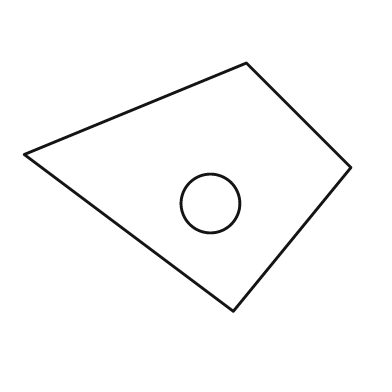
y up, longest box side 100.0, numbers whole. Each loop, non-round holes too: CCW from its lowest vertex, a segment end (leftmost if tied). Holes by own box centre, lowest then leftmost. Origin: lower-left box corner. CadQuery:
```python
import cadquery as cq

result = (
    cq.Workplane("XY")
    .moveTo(64.0, 0.0)
    .lineTo(100.0, 44.0)
    .lineTo(68.0, 76.0)
    .lineTo(0.0, 48.0)
    .close()
    .moveTo(57.0, 33.0)
    .circle(9.0)
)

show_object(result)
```